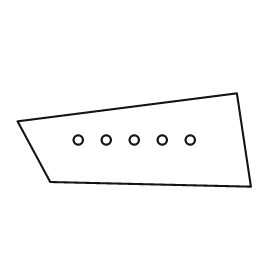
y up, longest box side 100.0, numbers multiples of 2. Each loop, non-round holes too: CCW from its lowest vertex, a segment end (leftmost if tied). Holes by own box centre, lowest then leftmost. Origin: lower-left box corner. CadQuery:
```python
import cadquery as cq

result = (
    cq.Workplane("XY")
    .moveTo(100.0, 0.0)
    .lineTo(94.0, 40.0)
    .lineTo(0.0, 28.0)
    .lineTo(14.0, 2.0)
    .close()
    .moveTo(26.0, 20.0)
    .circle(2.0)
    .moveTo(38.0, 20.0)
    .circle(2.0)
    .moveTo(50.0, 20.0)
    .circle(2.0)
    .moveTo(62.0, 20.0)
    .circle(2.0)
    .moveTo(74.0, 20.0)
    .circle(2.0)
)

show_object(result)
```